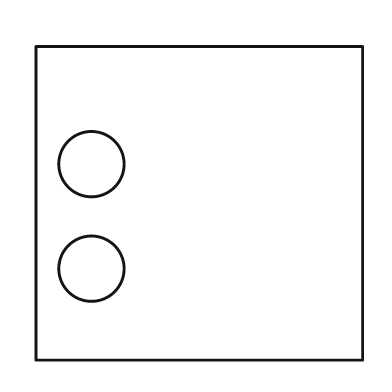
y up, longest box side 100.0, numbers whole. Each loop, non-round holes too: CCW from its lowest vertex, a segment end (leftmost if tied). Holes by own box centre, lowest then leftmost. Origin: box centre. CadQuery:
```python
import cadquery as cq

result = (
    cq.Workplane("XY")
    .moveTo(-50.0, -48.0)
    .lineTo(50.0, -48.0)
    .lineTo(50.0, 48.0)
    .lineTo(-50.0, 48.0)
    .close()
    .moveTo(-33.0, -20.0)
    .circle(10.0)
    .moveTo(-33.0, 12.0)
    .circle(10.0)
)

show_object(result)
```